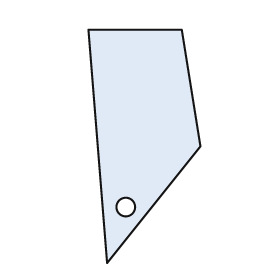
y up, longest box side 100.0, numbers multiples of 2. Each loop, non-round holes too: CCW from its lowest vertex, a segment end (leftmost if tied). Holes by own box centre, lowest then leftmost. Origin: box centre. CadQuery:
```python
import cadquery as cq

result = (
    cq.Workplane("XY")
    .moveTo(-16.0, -50.0)
    .lineTo(24.0, 0.0)
    .lineTo(16.0, 50.0)
    .lineTo(-24.0, 50.0)
    .close()
    .moveTo(-8.0, -26.0)
    .circle(4.0)
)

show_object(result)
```